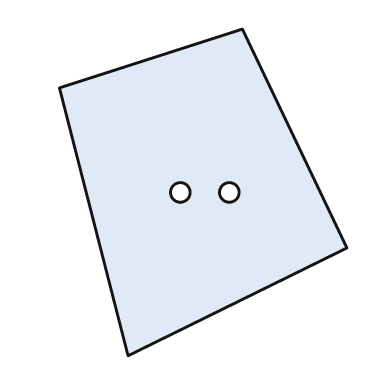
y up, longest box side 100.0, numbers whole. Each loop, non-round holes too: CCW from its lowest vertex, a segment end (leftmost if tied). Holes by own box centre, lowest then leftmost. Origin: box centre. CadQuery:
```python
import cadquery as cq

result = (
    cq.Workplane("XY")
    .moveTo(-23.0, -50.0)
    .lineTo(44.0, -17.0)
    .lineTo(12.0, 50.0)
    .lineTo(-44.0, 32.0)
    .close()
    .moveTo(-7.0, 0.0)
    .circle(3.0)
    .moveTo(8.0, 0.0)
    .circle(3.0)
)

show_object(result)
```